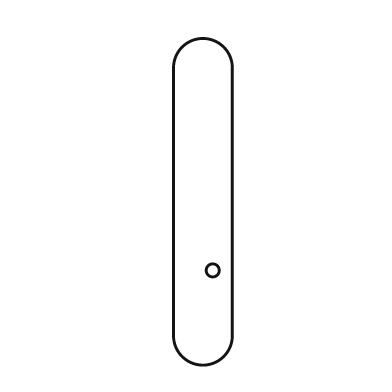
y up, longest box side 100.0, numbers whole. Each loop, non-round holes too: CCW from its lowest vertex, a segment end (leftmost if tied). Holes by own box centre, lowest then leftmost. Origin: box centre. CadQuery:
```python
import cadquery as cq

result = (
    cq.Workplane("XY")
    .moveTo(-9.0, -41.0)
    .threePointArc((0.0, -50.0), (9.0, -41.0))
    .lineTo(9.0, 41.0)
    .threePointArc((0.0, 50.0), (-9.0, 41.0))
    .close()
    .moveTo(3.0, -21.0)
    .circle(2.0)
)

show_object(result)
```